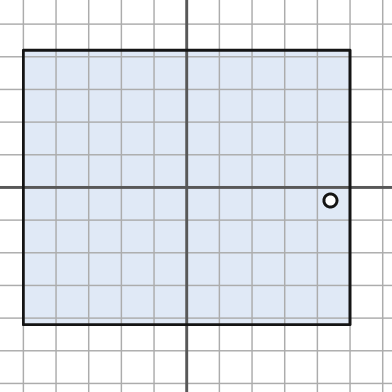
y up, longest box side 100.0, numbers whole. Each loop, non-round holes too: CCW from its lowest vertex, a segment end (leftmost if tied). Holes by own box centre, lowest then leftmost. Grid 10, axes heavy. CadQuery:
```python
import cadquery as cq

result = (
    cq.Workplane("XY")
    .moveTo(-50.0, -42.0)
    .lineTo(50.0, -42.0)
    .lineTo(50.0, 42.0)
    .lineTo(-50.0, 42.0)
    .close()
    .moveTo(44.0, -4.0)
    .circle(2.0)
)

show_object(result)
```